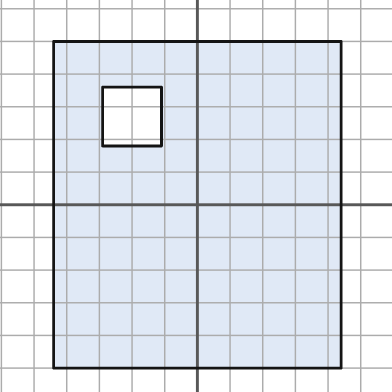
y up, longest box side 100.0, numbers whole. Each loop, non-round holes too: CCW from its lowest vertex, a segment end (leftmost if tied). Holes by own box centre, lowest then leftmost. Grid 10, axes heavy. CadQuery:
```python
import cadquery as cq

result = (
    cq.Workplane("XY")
    .moveTo(-44.0, -50.0)
    .lineTo(44.0, -50.0)
    .lineTo(44.0, 50.0)
    .lineTo(-44.0, 50.0)
    .close()
    .moveTo(-29.0, 18.0)
    .lineTo(-11.0, 18.0)
    .lineTo(-11.0, 36.0)
    .lineTo(-29.0, 36.0)
    .close()
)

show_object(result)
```